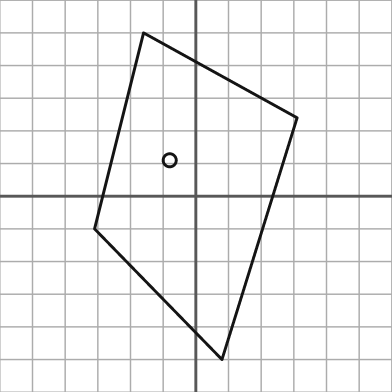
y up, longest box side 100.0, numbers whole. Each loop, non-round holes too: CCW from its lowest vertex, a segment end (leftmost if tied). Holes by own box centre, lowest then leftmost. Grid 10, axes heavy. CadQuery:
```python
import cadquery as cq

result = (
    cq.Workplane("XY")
    .moveTo(8.0, -50.0)
    .lineTo(31.0, 24.0)
    .lineTo(-16.0, 50.0)
    .lineTo(-31.0, -10.0)
    .close()
    .moveTo(-8.0, 11.0)
    .circle(2.0)
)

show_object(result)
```